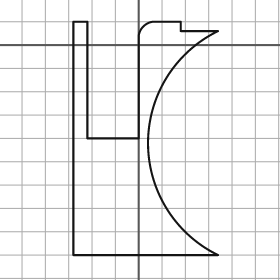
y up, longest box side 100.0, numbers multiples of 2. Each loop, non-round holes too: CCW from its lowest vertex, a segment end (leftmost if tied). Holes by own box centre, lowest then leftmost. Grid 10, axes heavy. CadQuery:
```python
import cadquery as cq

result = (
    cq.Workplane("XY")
    .moveTo(-28.0, -90.0)
    .lineTo(34.0, -90.0)
    .threePointArc((4.0, -42.0), (34.0, 6.0))
    .lineTo(18.0, 6.0)
    .lineTo(18.0, 10.0)
    .lineTo(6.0, 10.0)
    .threePointArc((2.0, 8.0), (0.0, 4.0))
    .lineTo(0.0, -40.0)
    .lineTo(-22.0, -40.0)
    .lineTo(-22.0, 10.0)
    .lineTo(-28.0, 10.0)
    .close()
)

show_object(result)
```